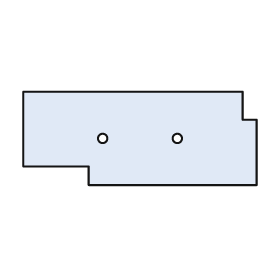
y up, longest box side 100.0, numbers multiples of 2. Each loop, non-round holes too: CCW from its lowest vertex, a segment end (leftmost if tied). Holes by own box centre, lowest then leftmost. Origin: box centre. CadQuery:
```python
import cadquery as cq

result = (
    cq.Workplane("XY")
    .moveTo(-22.0, -20.0)
    .lineTo(50.0, -20.0)
    .lineTo(50.0, 8.0)
    .lineTo(44.0, 8.0)
    .lineTo(44.0, 20.0)
    .lineTo(-50.0, 20.0)
    .lineTo(-50.0, -12.0)
    .lineTo(-22.0, -12.0)
    .close()
    .moveTo(-16.0, 0.0)
    .circle(2.0)
    .moveTo(16.0, 0.0)
    .circle(2.0)
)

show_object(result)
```